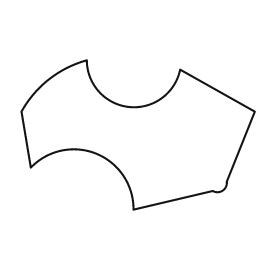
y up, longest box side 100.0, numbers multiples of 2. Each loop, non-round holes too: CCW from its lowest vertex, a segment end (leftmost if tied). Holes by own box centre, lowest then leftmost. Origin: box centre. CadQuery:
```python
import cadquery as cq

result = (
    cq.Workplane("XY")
    .moveTo(-2.0, -32.0)
    .lineTo(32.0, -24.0)
    .threePointArc((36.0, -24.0), (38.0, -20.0))
    .lineTo(50.0, 10.0)
    .lineTo(18.0, 28.0)
    .threePointArc((-4.0, 12.0), (-22.0, 32.0))
    .threePointArc((-38.0, 24.0), (-50.0, 10.0))
    .lineTo(-46.0, -14.0)
    .threePointArc((-18.0, -8.0), (-2.0, -32.0))
    .close()
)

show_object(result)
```